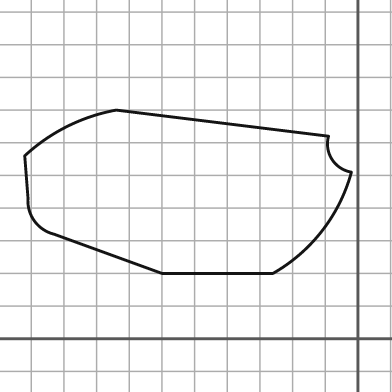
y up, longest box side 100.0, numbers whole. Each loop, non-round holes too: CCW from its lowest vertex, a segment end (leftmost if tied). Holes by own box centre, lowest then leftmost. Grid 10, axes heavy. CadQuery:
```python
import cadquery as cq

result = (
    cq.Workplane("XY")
    .moveTo(-60.0, 20.0)
    .lineTo(-26.0, 20.0)
    .threePointArc((-11.0, 33.0), (-2.0, 51.0))
    .threePointArc((-8.0, 55.0), (-9.0, 62.0))
    .lineTo(-74.0, 70.0)
    .threePointArc((-89.0, 65.0), (-102.0, 56.0))
    .lineTo(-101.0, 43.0)
    .threePointArc((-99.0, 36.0), (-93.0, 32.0))
    .close()
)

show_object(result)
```